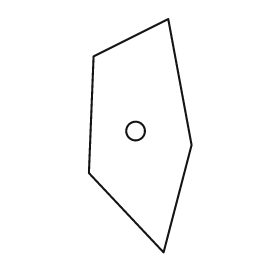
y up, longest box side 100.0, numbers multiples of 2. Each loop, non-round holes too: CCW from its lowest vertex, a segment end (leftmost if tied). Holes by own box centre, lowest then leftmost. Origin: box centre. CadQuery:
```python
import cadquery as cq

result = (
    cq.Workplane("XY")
    .moveTo(10.0, -50.0)
    .lineTo(22.0, -4.0)
    .lineTo(12.0, 50.0)
    .lineTo(-20.0, 34.0)
    .lineTo(-22.0, -16.0)
    .close()
    .moveTo(-2.0, 2.0)
    .circle(4.0)
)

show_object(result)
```